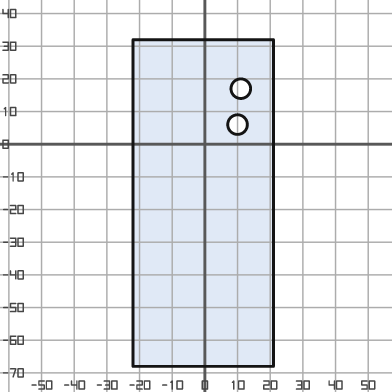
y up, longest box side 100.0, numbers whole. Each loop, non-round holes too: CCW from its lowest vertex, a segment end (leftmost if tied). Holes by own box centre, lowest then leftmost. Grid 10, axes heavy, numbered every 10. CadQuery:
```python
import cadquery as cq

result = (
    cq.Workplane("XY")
    .moveTo(-22.0, -68.0)
    .lineTo(21.0, -68.0)
    .lineTo(21.0, 32.0)
    .lineTo(-22.0, 32.0)
    .close()
    .moveTo(10.0, 6.0)
    .circle(3.0)
    .moveTo(11.0, 17.0)
    .circle(3.0)
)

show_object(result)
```